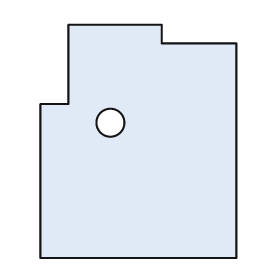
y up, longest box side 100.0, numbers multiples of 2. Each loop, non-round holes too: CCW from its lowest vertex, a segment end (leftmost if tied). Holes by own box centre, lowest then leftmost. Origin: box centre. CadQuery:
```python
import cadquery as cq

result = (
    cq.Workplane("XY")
    .moveTo(-42.0, -50.0)
    .lineTo(42.0, -50.0)
    .lineTo(42.0, 42.0)
    .lineTo(10.0, 42.0)
    .lineTo(10.0, 50.0)
    .lineTo(-30.0, 50.0)
    .lineTo(-30.0, 16.0)
    .lineTo(-42.0, 16.0)
    .close()
    .moveTo(-12.0, 8.0)
    .circle(6.0)
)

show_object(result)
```